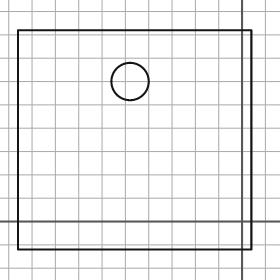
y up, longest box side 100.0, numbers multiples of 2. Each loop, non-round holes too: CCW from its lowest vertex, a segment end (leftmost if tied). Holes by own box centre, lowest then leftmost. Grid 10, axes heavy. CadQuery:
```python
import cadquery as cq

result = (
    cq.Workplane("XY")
    .moveTo(-96.0, -12.0)
    .lineTo(4.0, -12.0)
    .lineTo(4.0, 82.0)
    .lineTo(-96.0, 82.0)
    .close()
    .moveTo(-48.0, 60.0)
    .circle(8.0)
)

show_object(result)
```